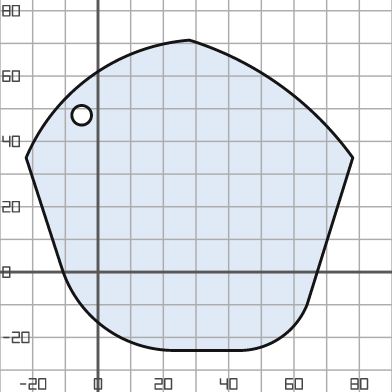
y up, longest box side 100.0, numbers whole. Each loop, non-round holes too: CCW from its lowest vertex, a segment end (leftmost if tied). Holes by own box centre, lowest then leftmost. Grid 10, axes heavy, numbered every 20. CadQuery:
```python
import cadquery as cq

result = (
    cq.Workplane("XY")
    .moveTo(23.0, -24.0)
    .lineTo(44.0, -24.0)
    .threePointArc((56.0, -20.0), (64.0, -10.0))
    .lineTo(78.0, 35.0)
    .threePointArc((56.0, 57.0), (28.0, 71.0))
    .threePointArc((-2.0, 60.0), (-22.0, 35.0))
    .lineTo(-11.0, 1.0)
    .threePointArc((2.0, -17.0), (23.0, -24.0))
    .close()
    .moveTo(-5.0, 48.0)
    .circle(3.0)
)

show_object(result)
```